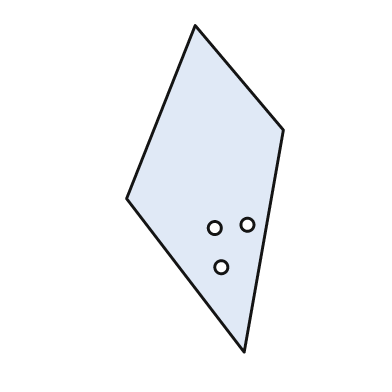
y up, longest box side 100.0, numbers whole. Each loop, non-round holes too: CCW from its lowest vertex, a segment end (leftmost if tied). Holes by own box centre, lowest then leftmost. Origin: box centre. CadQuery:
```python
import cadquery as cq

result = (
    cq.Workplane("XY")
    .moveTo(12.0, -50.0)
    .lineTo(24.0, 18.0)
    .lineTo(-3.0, 50.0)
    .lineTo(-24.0, -3.0)
    .close()
    .moveTo(5.0, -24.0)
    .circle(2.0)
    .moveTo(3.0, -12.0)
    .circle(2.0)
    .moveTo(13.0, -11.0)
    .circle(2.0)
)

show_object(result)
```